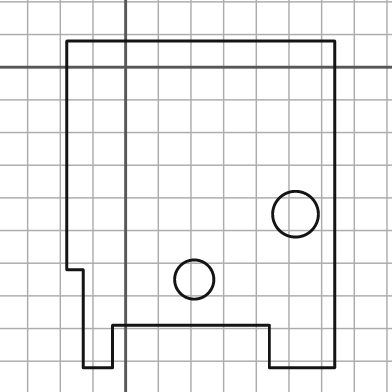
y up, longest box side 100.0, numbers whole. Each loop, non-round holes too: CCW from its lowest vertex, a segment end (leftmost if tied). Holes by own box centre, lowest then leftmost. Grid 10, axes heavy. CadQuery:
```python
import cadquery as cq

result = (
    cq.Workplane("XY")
    .moveTo(-13.0, -92.0)
    .lineTo(-4.0, -92.0)
    .lineTo(-4.0, -79.0)
    .lineTo(44.0, -79.0)
    .lineTo(44.0, -92.0)
    .lineTo(64.0, -92.0)
    .lineTo(64.0, 8.0)
    .lineTo(-18.0, 8.0)
    .lineTo(-18.0, -62.0)
    .lineTo(-13.0, -62.0)
    .close()
    .moveTo(21.0, -65.0)
    .circle(6.0)
    .moveTo(52.0, -45.0)
    .circle(7.0)
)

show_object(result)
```